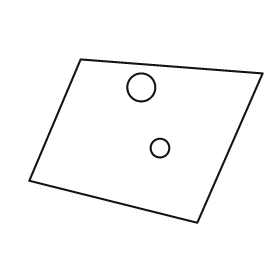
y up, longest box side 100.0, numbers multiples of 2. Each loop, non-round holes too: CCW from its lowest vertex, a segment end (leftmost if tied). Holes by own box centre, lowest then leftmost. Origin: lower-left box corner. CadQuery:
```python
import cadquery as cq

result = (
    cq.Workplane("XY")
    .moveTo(72.0, 0.0)
    .lineTo(100.0, 64.0)
    .lineTo(22.0, 70.0)
    .lineTo(0.0, 18.0)
    .close()
    .moveTo(56.0, 32.0)
    .circle(4.0)
    .moveTo(48.0, 58.0)
    .circle(6.0)
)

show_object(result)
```